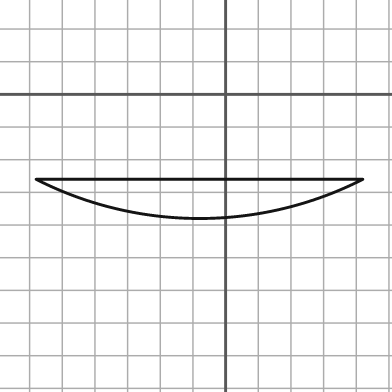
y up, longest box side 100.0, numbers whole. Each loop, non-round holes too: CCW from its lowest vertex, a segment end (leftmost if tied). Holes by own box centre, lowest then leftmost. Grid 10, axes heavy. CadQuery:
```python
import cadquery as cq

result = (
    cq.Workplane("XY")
    .moveTo(-58.0, -26.0)
    .threePointArc((-8.0, -38.0), (42.0, -26.0))
    .close()
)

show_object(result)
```